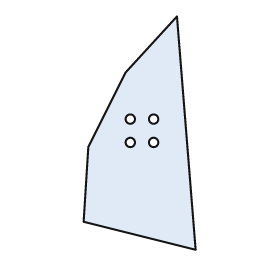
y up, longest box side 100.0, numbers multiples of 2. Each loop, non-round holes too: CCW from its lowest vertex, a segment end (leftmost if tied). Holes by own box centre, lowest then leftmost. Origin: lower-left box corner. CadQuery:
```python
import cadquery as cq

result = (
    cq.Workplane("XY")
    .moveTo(48.0, 0.0)
    .lineTo(40.0, 100.0)
    .lineTo(18.0, 76.0)
    .lineTo(2.0, 44.0)
    .lineTo(0.0, 12.0)
    .close()
    .moveTo(20.0, 46.0)
    .circle(2.0)
    .moveTo(30.0, 46.0)
    .circle(2.0)
    .moveTo(20.0, 56.0)
    .circle(2.0)
    .moveTo(30.0, 56.0)
    .circle(2.0)
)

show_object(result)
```